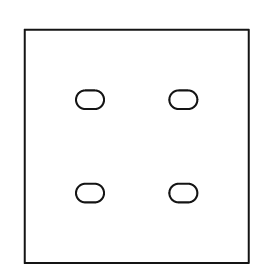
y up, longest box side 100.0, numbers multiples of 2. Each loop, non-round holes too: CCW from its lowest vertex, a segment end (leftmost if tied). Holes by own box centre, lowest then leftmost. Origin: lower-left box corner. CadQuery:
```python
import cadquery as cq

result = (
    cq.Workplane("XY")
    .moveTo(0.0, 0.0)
    .lineTo(96.0, 0.0)
    .lineTo(96.0, 100.0)
    .lineTo(0.0, 100.0)
    .close()
    .moveTo(26.0, 26.0)
    .lineTo(30.0, 26.0)
    .threePointArc((34.0, 30.0), (30.0, 34.0))
    .lineTo(26.0, 34.0)
    .threePointArc((22.0, 30.0), (26.0, 26.0))
    .close()
    .moveTo(66.0, 26.0)
    .lineTo(70.0, 26.0)
    .threePointArc((74.0, 30.0), (70.0, 34.0))
    .lineTo(66.0, 34.0)
    .threePointArc((62.0, 30.0), (66.0, 26.0))
    .close()
    .moveTo(26.0, 66.0)
    .lineTo(30.0, 66.0)
    .threePointArc((34.0, 70.0), (30.0, 74.0))
    .lineTo(26.0, 74.0)
    .threePointArc((22.0, 70.0), (26.0, 66.0))
    .close()
    .moveTo(66.0, 66.0)
    .lineTo(70.0, 66.0)
    .threePointArc((74.0, 70.0), (70.0, 74.0))
    .lineTo(66.0, 74.0)
    .threePointArc((62.0, 70.0), (66.0, 66.0))
    .close()
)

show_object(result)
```